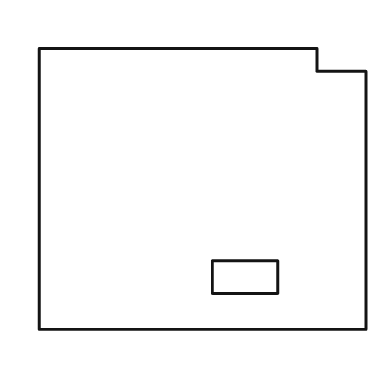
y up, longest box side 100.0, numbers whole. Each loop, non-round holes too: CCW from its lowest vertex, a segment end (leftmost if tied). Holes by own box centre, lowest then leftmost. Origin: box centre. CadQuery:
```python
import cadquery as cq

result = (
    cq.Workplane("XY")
    .moveTo(-50.0, -43.0)
    .lineTo(50.0, -43.0)
    .lineTo(50.0, 36.0)
    .lineTo(35.0, 36.0)
    .lineTo(35.0, 43.0)
    .lineTo(-50.0, 43.0)
    .close()
    .moveTo(3.0, -32.0)
    .lineTo(23.0, -32.0)
    .lineTo(23.0, -22.0)
    .lineTo(3.0, -22.0)
    .close()
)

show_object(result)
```